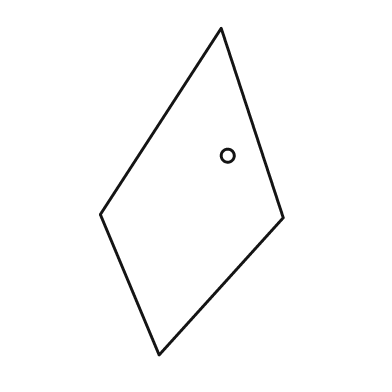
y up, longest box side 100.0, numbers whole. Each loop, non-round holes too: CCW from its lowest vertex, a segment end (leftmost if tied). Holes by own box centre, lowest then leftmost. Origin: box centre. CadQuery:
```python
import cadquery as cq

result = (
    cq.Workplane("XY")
    .moveTo(-10.0, -50.0)
    .lineTo(28.0, -8.0)
    .lineTo(9.0, 50.0)
    .lineTo(-28.0, -7.0)
    .close()
    .moveTo(11.0, 11.0)
    .circle(2.0)
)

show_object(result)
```